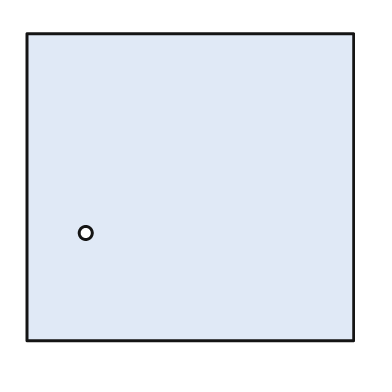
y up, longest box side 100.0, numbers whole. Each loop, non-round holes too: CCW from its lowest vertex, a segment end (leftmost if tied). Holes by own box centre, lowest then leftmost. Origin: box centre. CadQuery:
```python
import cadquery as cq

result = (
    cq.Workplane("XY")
    .moveTo(-50.0, -47.0)
    .lineTo(50.0, -47.0)
    .lineTo(50.0, 47.0)
    .lineTo(-50.0, 47.0)
    .close()
    .moveTo(-32.0, -14.0)
    .circle(2.0)
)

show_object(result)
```